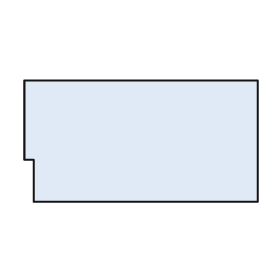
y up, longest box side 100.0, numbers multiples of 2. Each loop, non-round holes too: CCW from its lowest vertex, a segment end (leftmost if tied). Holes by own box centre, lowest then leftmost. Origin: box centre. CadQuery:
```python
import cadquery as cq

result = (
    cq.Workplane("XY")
    .moveTo(-46.0, -26.0)
    .lineTo(50.0, -26.0)
    .lineTo(50.0, 26.0)
    .lineTo(-50.0, 26.0)
    .lineTo(-50.0, -8.0)
    .lineTo(-46.0, -8.0)
    .close()
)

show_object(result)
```